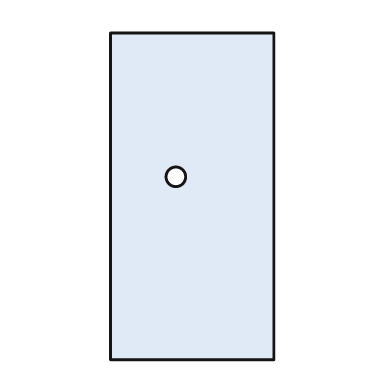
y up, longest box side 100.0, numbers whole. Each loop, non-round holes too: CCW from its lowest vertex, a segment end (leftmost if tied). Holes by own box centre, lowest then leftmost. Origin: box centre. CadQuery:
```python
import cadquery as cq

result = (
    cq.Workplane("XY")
    .moveTo(-25.0, -50.0)
    .lineTo(25.0, -50.0)
    .lineTo(25.0, 50.0)
    .lineTo(-25.0, 50.0)
    .close()
    .moveTo(-5.0, 6.0)
    .circle(3.0)
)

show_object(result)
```